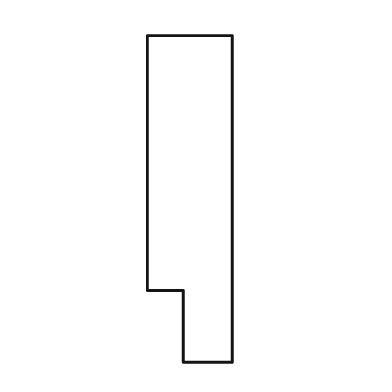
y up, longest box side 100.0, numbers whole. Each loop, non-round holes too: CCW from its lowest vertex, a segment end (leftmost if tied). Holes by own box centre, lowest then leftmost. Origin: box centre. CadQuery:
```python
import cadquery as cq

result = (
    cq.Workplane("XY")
    .moveTo(-2.0, -50.0)
    .lineTo(13.0, -50.0)
    .lineTo(13.0, 50.0)
    .lineTo(-13.0, 50.0)
    .lineTo(-13.0, -28.0)
    .lineTo(-2.0, -28.0)
    .close()
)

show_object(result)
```